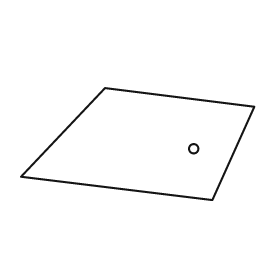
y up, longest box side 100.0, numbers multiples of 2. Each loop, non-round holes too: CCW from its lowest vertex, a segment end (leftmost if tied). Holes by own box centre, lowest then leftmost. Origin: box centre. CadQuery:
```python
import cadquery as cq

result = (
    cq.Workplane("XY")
    .moveTo(32.0, -24.0)
    .lineTo(50.0, 16.0)
    .lineTo(-14.0, 24.0)
    .lineTo(-50.0, -14.0)
    .close()
    .moveTo(24.0, -2.0)
    .circle(2.0)
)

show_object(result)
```